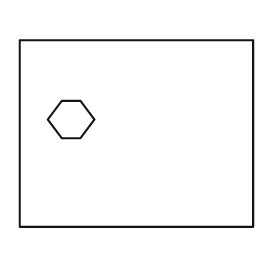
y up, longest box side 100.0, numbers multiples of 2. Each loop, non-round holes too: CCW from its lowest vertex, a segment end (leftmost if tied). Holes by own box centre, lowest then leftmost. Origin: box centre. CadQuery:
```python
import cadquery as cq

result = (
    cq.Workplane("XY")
    .moveTo(-50.0, -40.0)
    .lineTo(50.0, -40.0)
    .lineTo(50.0, 40.0)
    .lineTo(-50.0, 40.0)
    .close()
    .moveTo(-32.0, -2.0)
    .lineTo(-24.0, -2.0)
    .lineTo(-18.0, 6.0)
    .lineTo(-24.0, 14.0)
    .lineTo(-32.0, 14.0)
    .lineTo(-38.0, 6.0)
    .close()
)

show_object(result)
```